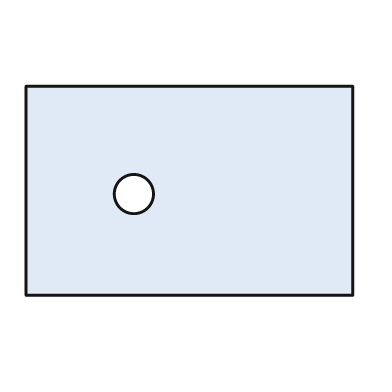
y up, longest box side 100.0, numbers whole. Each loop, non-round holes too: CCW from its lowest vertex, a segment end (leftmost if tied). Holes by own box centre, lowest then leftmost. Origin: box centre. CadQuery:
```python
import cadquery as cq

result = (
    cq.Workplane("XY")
    .moveTo(-50.0, -32.0)
    .lineTo(50.0, -32.0)
    .lineTo(50.0, 32.0)
    .lineTo(-50.0, 32.0)
    .close()
    .moveTo(-17.0, -1.0)
    .circle(6.0)
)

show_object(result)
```